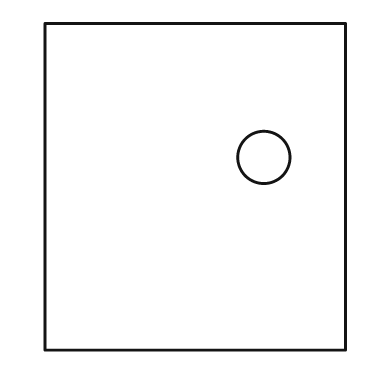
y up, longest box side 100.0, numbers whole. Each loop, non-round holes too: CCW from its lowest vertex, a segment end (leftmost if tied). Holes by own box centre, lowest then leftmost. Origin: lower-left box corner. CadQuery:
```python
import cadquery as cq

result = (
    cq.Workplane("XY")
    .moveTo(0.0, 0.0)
    .lineTo(92.0, 0.0)
    .lineTo(92.0, 100.0)
    .lineTo(0.0, 100.0)
    .close()
    .moveTo(67.0, 59.0)
    .circle(8.0)
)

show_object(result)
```